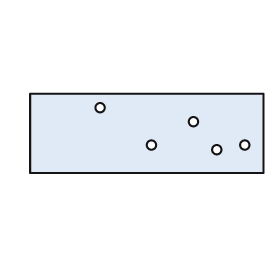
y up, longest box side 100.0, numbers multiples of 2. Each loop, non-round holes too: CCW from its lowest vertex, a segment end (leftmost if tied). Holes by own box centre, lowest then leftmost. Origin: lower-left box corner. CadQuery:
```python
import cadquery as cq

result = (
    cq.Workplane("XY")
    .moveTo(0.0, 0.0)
    .lineTo(100.0, 0.0)
    .lineTo(100.0, 34.0)
    .lineTo(0.0, 34.0)
    .close()
    .moveTo(80.0, 10.0)
    .circle(2.0)
    .moveTo(52.0, 12.0)
    .circle(2.0)
    .moveTo(92.0, 12.0)
    .circle(2.0)
    .moveTo(70.0, 22.0)
    .circle(2.0)
    .moveTo(30.0, 28.0)
    .circle(2.0)
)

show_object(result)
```